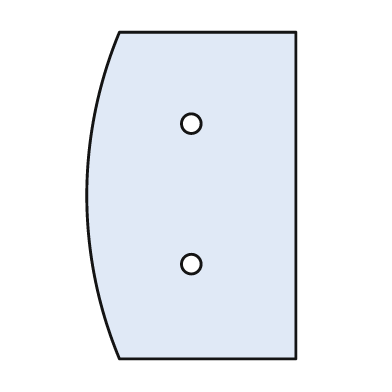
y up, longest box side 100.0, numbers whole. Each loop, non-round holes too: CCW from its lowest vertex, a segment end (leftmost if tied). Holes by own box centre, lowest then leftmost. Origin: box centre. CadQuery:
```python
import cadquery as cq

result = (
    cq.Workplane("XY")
    .moveTo(-22.0, -50.0)
    .lineTo(32.0, -50.0)
    .lineTo(32.0, 50.0)
    .lineTo(-22.0, 50.0)
    .threePointArc((-32.0, 0.0), (-22.0, -50.0))
    .close()
    .moveTo(0.0, -21.0)
    .circle(3.0)
    .moveTo(0.0, 22.0)
    .circle(3.0)
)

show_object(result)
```